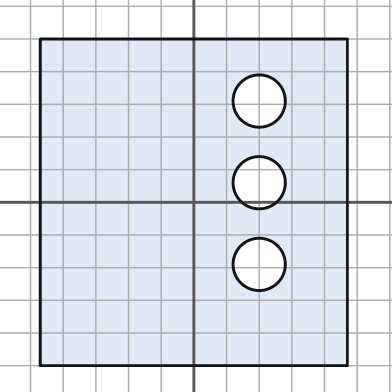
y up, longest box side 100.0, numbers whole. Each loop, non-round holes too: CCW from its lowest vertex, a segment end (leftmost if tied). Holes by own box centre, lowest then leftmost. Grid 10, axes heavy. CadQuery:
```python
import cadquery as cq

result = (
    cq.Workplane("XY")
    .moveTo(-47.0, -50.0)
    .lineTo(47.0, -50.0)
    .lineTo(47.0, 50.0)
    .lineTo(-47.0, 50.0)
    .close()
    .moveTo(20.0, -19.0)
    .circle(8.0)
    .moveTo(20.0, 6.0)
    .circle(8.0)
    .moveTo(20.0, 31.0)
    .circle(8.0)
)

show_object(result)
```